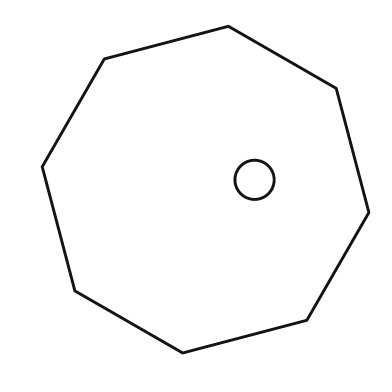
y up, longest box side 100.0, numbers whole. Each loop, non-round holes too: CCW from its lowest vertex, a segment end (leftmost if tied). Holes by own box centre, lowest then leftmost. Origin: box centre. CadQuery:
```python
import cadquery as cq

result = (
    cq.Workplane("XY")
    .moveTo(-7.0, -50.0)
    .lineTo(31.0, -40.0)
    .lineTo(50.0, -7.0)
    .lineTo(40.0, 31.0)
    .lineTo(7.0, 50.0)
    .lineTo(-31.0, 40.0)
    .lineTo(-50.0, 7.0)
    .lineTo(-40.0, -31.0)
    .close()
    .moveTo(15.0, 3.0)
    .circle(6.0)
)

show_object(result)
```